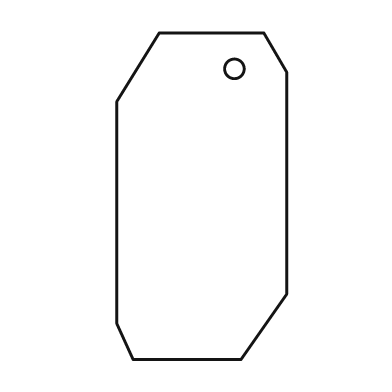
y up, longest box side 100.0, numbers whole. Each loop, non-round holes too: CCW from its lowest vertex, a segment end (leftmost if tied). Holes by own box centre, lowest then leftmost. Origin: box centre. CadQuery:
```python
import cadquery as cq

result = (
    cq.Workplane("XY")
    .moveTo(-21.0, -50.0)
    .lineTo(12.0, -50.0)
    .lineTo(26.0, -30.0)
    .lineTo(26.0, 38.0)
    .lineTo(19.0, 50.0)
    .lineTo(-13.0, 50.0)
    .lineTo(-26.0, 29.0)
    .lineTo(-26.0, -39.0)
    .close()
    .moveTo(10.0, 39.0)
    .circle(3.0)
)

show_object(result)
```